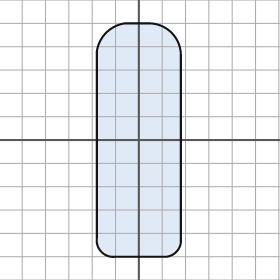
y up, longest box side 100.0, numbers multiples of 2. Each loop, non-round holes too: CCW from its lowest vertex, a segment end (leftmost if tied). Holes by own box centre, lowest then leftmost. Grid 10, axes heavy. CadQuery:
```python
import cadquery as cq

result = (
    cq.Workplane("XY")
    .moveTo(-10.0, -50.0)
    .lineTo(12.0, -50.0)
    .threePointArc((16.0, -48.0), (18.0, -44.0))
    .lineTo(18.0, 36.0)
    .threePointArc((14.0, 46.0), (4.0, 50.0))
    .lineTo(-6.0, 50.0)
    .threePointArc((-14.0, 46.0), (-18.0, 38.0))
    .lineTo(-18.0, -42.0)
    .threePointArc((-16.0, -48.0), (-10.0, -50.0))
    .close()
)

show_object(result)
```